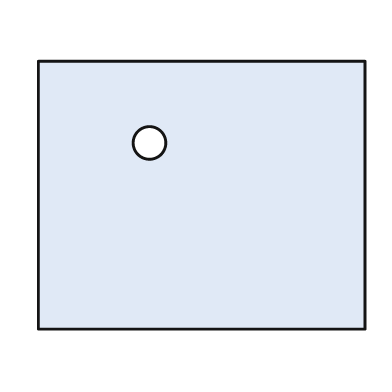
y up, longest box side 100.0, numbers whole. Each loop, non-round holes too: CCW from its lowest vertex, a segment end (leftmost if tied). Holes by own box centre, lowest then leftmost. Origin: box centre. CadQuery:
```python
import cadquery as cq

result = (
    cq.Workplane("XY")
    .moveTo(-50.0, -41.0)
    .lineTo(50.0, -41.0)
    .lineTo(50.0, 41.0)
    .lineTo(-50.0, 41.0)
    .close()
    .moveTo(-16.0, 16.0)
    .circle(5.0)
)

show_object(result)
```